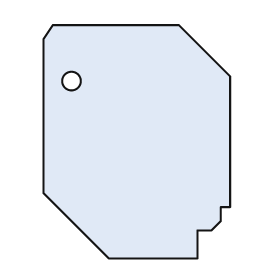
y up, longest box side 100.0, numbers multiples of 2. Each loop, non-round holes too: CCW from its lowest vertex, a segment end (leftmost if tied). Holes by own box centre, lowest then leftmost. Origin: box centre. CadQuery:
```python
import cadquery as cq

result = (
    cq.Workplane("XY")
    .moveTo(-12.0, -50.0)
    .lineTo(26.0, -50.0)
    .lineTo(26.0, -38.0)
    .lineTo(32.0, -38.0)
    .lineTo(36.0, -34.0)
    .lineTo(36.0, -28.0)
    .lineTo(40.0, -28.0)
    .lineTo(40.0, 28.0)
    .lineTo(18.0, 50.0)
    .lineTo(-36.0, 50.0)
    .lineTo(-40.0, 44.0)
    .lineTo(-40.0, -22.0)
    .close()
    .moveTo(-28.0, 26.0)
    .circle(4.0)
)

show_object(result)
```